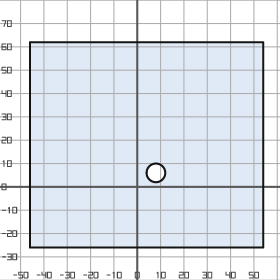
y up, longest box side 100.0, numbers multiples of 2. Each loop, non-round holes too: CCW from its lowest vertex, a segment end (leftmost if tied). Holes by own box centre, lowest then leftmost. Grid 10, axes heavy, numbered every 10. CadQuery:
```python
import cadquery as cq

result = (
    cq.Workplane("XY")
    .moveTo(-46.0, -26.0)
    .lineTo(54.0, -26.0)
    .lineTo(54.0, 62.0)
    .lineTo(-46.0, 62.0)
    .close()
    .moveTo(8.0, 6.0)
    .circle(4.0)
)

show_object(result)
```